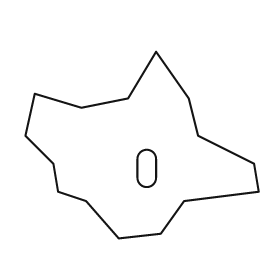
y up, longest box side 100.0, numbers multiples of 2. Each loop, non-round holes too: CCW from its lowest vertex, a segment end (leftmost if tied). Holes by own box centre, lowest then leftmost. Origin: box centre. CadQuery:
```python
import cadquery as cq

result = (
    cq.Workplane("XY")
    .moveTo(-10.0, -40.0)
    .lineTo(8.0, -38.0)
    .lineTo(18.0, -24.0)
    .lineTo(50.0, -20.0)
    .lineTo(48.0, -8.0)
    .lineTo(24.0, 4.0)
    .lineTo(20.0, 20.0)
    .lineTo(6.0, 40.0)
    .lineTo(-6.0, 20.0)
    .lineTo(-26.0, 16.0)
    .lineTo(-46.0, 22.0)
    .lineTo(-50.0, 4.0)
    .lineTo(-38.0, -8.0)
    .lineTo(-36.0, -20.0)
    .lineTo(-24.0, -24.0)
    .close()
    .moveTo(-2.0, -14.0)
    .threePointArc((2.0, -18.0), (6.0, -14.0))
    .lineTo(6.0, -6.0)
    .threePointArc((2.0, -2.0), (-2.0, -6.0))
    .close()
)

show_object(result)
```